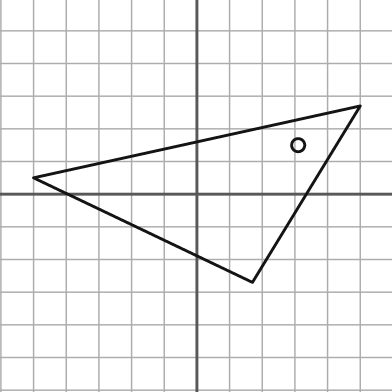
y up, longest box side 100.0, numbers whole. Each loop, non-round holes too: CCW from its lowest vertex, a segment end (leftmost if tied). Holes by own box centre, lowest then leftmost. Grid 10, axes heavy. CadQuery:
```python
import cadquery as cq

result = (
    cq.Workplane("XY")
    .moveTo(17.0, -27.0)
    .lineTo(50.0, 27.0)
    .lineTo(-50.0, 5.0)
    .close()
    .moveTo(31.0, 15.0)
    .circle(2.0)
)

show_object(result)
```